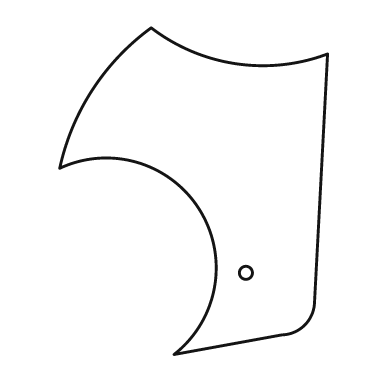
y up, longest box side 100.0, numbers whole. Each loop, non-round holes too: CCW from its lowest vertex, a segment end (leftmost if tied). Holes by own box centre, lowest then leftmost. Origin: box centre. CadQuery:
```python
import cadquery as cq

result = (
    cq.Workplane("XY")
    .moveTo(-6.0, -50.0)
    .lineTo(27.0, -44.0)
    .threePointArc((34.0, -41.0), (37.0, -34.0))
    .lineTo(41.0, 42.0)
    .threePointArc((13.0, 39.0), (-13.0, 50.0))
    .threePointArc((-31.0, 31.0), (-41.0, 7.0))
    .threePointArc((2.0, -6.0), (-6.0, -50.0))
    .close()
    .moveTo(16.0, -25.0)
    .circle(2.0)
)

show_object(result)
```